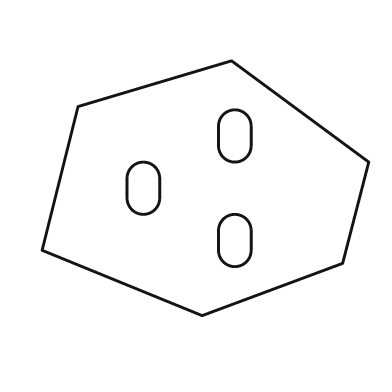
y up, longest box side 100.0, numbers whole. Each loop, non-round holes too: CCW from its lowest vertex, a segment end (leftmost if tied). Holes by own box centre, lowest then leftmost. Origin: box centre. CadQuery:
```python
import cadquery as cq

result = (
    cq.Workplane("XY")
    .moveTo(-1.0, -39.0)
    .lineTo(42.0, -23.0)
    .lineTo(50.0, 8.0)
    .lineTo(8.0, 39.0)
    .lineTo(-39.0, 25.0)
    .lineTo(-50.0, -19.0)
    .close()
    .moveTo(4.0, -19.0)
    .threePointArc((9.0, -24.0), (14.0, -19.0))
    .lineTo(14.0, -13.0)
    .threePointArc((9.0, -8.0), (4.0, -13.0))
    .close()
    .moveTo(-24.0, -3.0)
    .threePointArc((-19.0, -8.0), (-14.0, -3.0))
    .lineTo(-14.0, 3.0)
    .threePointArc((-19.0, 8.0), (-24.0, 3.0))
    .close()
    .moveTo(4.0, 13.0)
    .threePointArc((9.0, 8.0), (14.0, 13.0))
    .lineTo(14.0, 19.0)
    .threePointArc((9.0, 24.0), (4.0, 19.0))
    .close()
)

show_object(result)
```